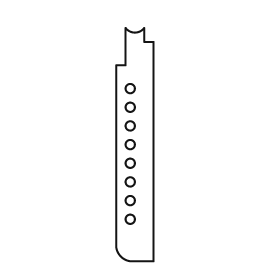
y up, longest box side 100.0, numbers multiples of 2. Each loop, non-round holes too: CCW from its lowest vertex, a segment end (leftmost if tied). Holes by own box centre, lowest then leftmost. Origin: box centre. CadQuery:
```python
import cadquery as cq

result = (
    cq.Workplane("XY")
    .moveTo(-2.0, -50.0)
    .lineTo(8.0, -50.0)
    .lineTo(8.0, 44.0)
    .lineTo(4.0, 44.0)
    .lineTo(4.0, 50.0)
    .threePointArc((0.0, 48.0), (-4.0, 50.0))
    .lineTo(-4.0, 34.0)
    .lineTo(-8.0, 34.0)
    .lineTo(-8.0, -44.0)
    .threePointArc((-6.0, -48.0), (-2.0, -50.0))
    .close()
    .moveTo(-2.0, -32.0)
    .circle(2.0)
    .moveTo(-2.0, -24.0)
    .circle(2.0)
    .moveTo(-2.0, -16.0)
    .circle(2.0)
    .moveTo(-2.0, -8.0)
    .circle(2.0)
    .moveTo(-2.0, 0.0)
    .circle(2.0)
    .moveTo(-2.0, 8.0)
    .circle(2.0)
    .moveTo(-2.0, 16.0)
    .circle(2.0)
    .moveTo(-2.0, 24.0)
    .circle(2.0)
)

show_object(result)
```